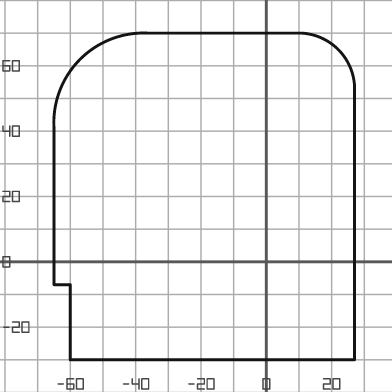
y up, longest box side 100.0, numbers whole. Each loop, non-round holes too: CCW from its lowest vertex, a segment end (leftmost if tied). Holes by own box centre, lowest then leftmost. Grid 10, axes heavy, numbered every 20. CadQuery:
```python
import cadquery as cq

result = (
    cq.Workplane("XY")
    .moveTo(-60.0, -30.0)
    .lineTo(27.0, -30.0)
    .lineTo(27.0, 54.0)
    .threePointArc((22.0, 65.0), (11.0, 70.0))
    .lineTo(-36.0, 70.0)
    .threePointArc((-57.0, 62.0), (-65.0, 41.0))
    .lineTo(-65.0, -7.0)
    .lineTo(-60.0, -7.0)
    .close()
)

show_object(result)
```